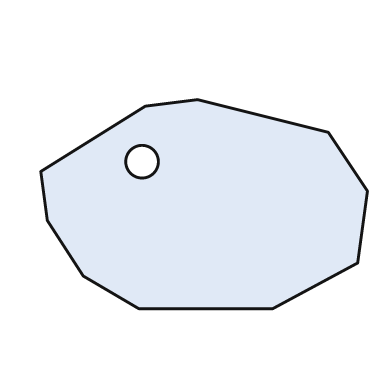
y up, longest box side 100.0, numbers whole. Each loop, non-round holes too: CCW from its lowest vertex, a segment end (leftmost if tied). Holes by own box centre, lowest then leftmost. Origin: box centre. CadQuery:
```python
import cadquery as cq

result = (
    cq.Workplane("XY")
    .moveTo(-20.0, -32.0)
    .lineTo(21.0, -32.0)
    .lineTo(47.0, -18.0)
    .lineTo(50.0, 4.0)
    .lineTo(38.0, 22.0)
    .lineTo(-2.0, 32.0)
    .lineTo(-18.0, 30.0)
    .lineTo(-50.0, 10.0)
    .lineTo(-48.0, -5.0)
    .lineTo(-37.0, -22.0)
    .close()
    .moveTo(-19.0, 13.0)
    .circle(5.0)
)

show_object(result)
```